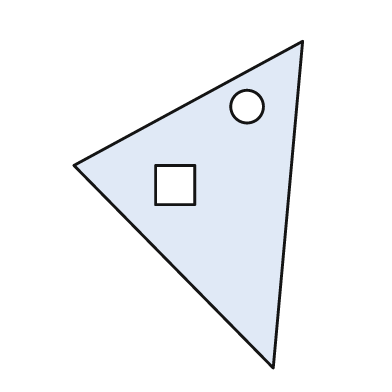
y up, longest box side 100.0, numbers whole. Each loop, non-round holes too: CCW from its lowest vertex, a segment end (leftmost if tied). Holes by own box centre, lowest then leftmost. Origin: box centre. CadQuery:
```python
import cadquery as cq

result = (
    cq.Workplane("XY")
    .moveTo(26.0, -50.0)
    .lineTo(35.0, 50.0)
    .lineTo(-35.0, 12.0)
    .close()
    .moveTo(-10.0, 0.0)
    .lineTo(2.0, 0.0)
    .lineTo(2.0, 12.0)
    .lineTo(-10.0, 12.0)
    .close()
    .moveTo(18.0, 30.0)
    .circle(5.0)
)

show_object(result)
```